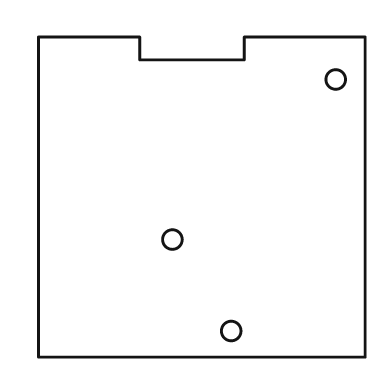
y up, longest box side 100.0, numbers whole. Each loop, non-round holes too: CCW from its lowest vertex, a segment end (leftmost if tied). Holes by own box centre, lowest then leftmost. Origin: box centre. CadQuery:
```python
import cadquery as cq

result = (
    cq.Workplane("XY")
    .moveTo(-50.0, -49.0)
    .lineTo(50.0, -49.0)
    .lineTo(50.0, 49.0)
    .lineTo(13.0, 49.0)
    .lineTo(13.0, 42.0)
    .lineTo(-19.0, 42.0)
    .lineTo(-19.0, 49.0)
    .lineTo(-50.0, 49.0)
    .close()
    .moveTo(9.0, -41.0)
    .circle(3.0)
    .moveTo(-9.0, -13.0)
    .circle(3.0)
    .moveTo(41.0, 36.0)
    .circle(3.0)
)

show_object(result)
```